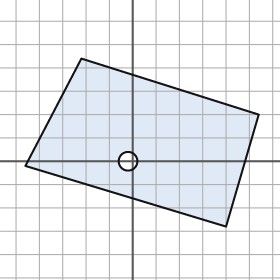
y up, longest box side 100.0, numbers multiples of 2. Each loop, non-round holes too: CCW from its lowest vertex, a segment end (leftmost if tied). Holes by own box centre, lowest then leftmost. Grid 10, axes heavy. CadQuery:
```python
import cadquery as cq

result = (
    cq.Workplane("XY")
    .moveTo(40.0, -28.0)
    .lineTo(54.0, 20.0)
    .lineTo(-22.0, 44.0)
    .lineTo(-46.0, -2.0)
    .close()
    .moveTo(-2.0, 0.0)
    .circle(4.0)
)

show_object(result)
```